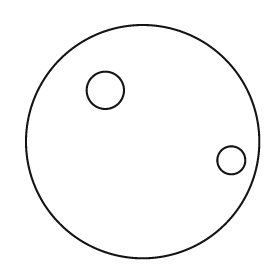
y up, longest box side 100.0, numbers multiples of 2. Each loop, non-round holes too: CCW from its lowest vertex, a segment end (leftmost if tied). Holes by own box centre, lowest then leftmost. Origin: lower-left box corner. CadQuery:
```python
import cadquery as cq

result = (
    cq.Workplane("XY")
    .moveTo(50.0, 50.0)
    .circle(50.0)
    .moveTo(88.0, 42.0)
    .circle(6.0)
    .moveTo(34.0, 72.0)
    .circle(8.0)
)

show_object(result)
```